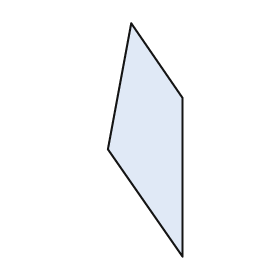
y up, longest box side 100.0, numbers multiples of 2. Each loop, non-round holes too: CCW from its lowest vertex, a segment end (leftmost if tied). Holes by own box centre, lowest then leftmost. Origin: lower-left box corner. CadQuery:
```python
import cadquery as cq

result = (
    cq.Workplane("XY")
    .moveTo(32.0, 0.0)
    .lineTo(32.0, 68.0)
    .lineTo(10.0, 100.0)
    .lineTo(0.0, 46.0)
    .close()
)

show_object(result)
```